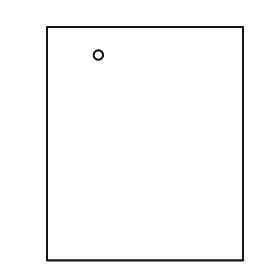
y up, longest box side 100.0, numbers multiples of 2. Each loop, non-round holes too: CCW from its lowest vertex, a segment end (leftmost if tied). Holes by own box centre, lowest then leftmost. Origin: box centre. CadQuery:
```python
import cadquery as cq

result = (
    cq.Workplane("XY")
    .moveTo(-42.0, -50.0)
    .lineTo(42.0, -50.0)
    .lineTo(42.0, 50.0)
    .lineTo(-42.0, 50.0)
    .close()
    .moveTo(-20.0, 38.0)
    .circle(2.0)
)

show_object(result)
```